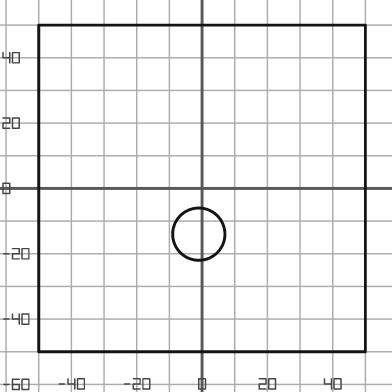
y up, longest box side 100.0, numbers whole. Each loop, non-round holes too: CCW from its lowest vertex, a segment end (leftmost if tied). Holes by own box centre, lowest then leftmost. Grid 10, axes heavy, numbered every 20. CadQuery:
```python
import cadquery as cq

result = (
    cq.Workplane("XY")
    .moveTo(-50.0, -50.0)
    .lineTo(50.0, -50.0)
    .lineTo(50.0, 50.0)
    .lineTo(-50.0, 50.0)
    .close()
    .moveTo(-1.0, -14.0)
    .circle(8.0)
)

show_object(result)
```